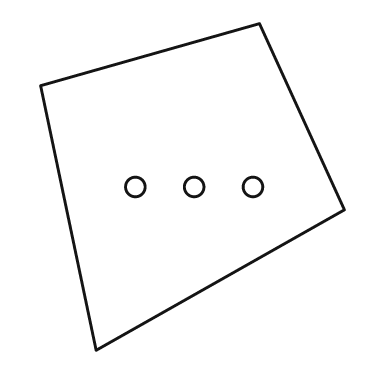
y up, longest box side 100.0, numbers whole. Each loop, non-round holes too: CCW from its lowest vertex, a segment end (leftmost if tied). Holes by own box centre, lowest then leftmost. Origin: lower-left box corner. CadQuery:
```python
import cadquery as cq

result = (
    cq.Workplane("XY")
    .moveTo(17.0, 0.0)
    .lineTo(93.0, 43.0)
    .lineTo(67.0, 100.0)
    .lineTo(0.0, 81.0)
    .close()
    .moveTo(29.0, 50.0)
    .circle(3.0)
    .moveTo(47.0, 50.0)
    .circle(3.0)
    .moveTo(65.0, 50.0)
    .circle(3.0)
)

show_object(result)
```